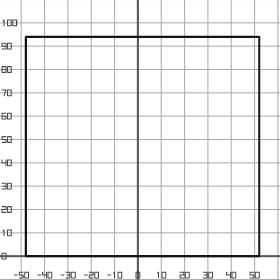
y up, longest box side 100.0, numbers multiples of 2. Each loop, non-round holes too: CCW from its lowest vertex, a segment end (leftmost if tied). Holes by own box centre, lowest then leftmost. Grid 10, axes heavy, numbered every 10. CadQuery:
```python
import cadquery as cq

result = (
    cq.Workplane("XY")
    .moveTo(-48.0, 0.0)
    .lineTo(52.0, 0.0)
    .lineTo(52.0, 94.0)
    .lineTo(-48.0, 94.0)
    .close()
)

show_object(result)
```